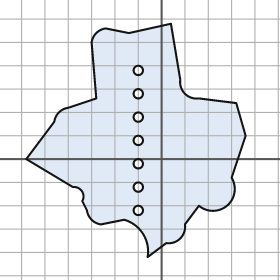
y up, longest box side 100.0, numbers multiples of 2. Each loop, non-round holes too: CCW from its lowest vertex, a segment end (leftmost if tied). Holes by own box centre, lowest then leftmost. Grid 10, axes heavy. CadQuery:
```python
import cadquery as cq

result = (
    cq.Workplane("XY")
    .moveTo(-6.0, -42.0)
    .lineTo(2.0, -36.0)
    .threePointArc((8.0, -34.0), (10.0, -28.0))
    .lineTo(16.0, -20.0)
    .threePointArc((28.0, -20.0), (30.0, -8.0))
    .lineTo(36.0, 10.0)
    .lineTo(32.0, 24.0)
    .lineTo(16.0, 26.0)
    .threePointArc((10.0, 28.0), (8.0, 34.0))
    .lineTo(4.0, 58.0)
    .lineTo(-14.0, 54.0)
    .lineTo(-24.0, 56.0)
    .threePointArc((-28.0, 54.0), (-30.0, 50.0))
    .lineTo(-28.0, 26.0)
    .lineTo(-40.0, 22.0)
    .threePointArc((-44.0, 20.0), (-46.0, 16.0))
    .lineTo(-58.0, 0.0)
    .lineTo(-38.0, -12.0)
    .threePointArc((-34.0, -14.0), (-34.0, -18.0))
    .lineTo(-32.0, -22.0)
    .threePointArc((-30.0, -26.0), (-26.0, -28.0))
    .lineTo(-16.0, -26.0)
    .threePointArc((-8.0, -32.0), (-6.0, -42.0))
    .close()
    .moveTo(-10.0, -22.0)
    .circle(2.0)
    .moveTo(-10.0, -12.0)
    .circle(2.0)
    .moveTo(-10.0, -2.0)
    .circle(2.0)
    .moveTo(-10.0, 8.0)
    .circle(2.0)
    .moveTo(-10.0, 18.0)
    .circle(2.0)
    .moveTo(-10.0, 28.0)
    .circle(2.0)
    .moveTo(-10.0, 38.0)
    .circle(2.0)
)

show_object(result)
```